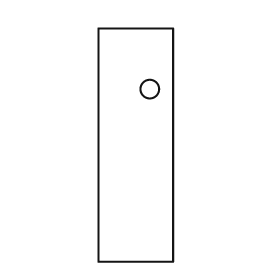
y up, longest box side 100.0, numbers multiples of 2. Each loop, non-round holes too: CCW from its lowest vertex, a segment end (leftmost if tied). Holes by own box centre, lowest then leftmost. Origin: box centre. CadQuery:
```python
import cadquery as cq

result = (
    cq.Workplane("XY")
    .moveTo(-16.0, -50.0)
    .lineTo(16.0, -50.0)
    .lineTo(16.0, 50.0)
    .lineTo(-16.0, 50.0)
    .close()
    .moveTo(6.0, 24.0)
    .circle(4.0)
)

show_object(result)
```